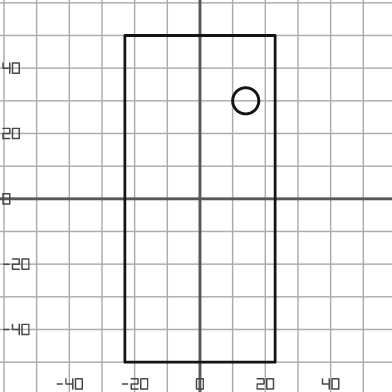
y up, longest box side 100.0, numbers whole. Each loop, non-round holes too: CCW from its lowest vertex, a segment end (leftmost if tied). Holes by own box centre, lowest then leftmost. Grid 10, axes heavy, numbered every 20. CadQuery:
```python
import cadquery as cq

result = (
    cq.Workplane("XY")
    .moveTo(-23.0, -50.0)
    .lineTo(23.0, -50.0)
    .lineTo(23.0, 50.0)
    .lineTo(-23.0, 50.0)
    .close()
    .moveTo(14.0, 30.0)
    .circle(4.0)
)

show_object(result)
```